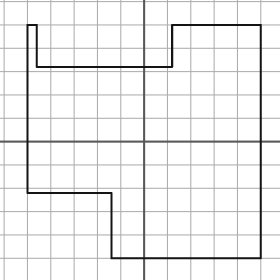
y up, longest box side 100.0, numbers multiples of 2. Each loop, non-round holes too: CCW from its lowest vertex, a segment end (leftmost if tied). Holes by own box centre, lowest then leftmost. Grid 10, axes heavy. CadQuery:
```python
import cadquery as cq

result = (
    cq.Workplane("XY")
    .moveTo(-14.0, -50.0)
    .lineTo(50.0, -50.0)
    .lineTo(50.0, 50.0)
    .lineTo(12.0, 50.0)
    .lineTo(12.0, 32.0)
    .lineTo(-46.0, 32.0)
    .lineTo(-46.0, 50.0)
    .lineTo(-50.0, 50.0)
    .lineTo(-50.0, -22.0)
    .lineTo(-14.0, -22.0)
    .close()
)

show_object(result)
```